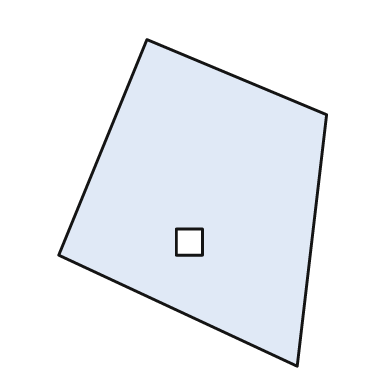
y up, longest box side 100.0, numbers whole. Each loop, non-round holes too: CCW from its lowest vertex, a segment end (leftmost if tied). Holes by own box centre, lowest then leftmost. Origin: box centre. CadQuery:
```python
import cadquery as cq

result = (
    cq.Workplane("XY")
    .moveTo(32.0, -50.0)
    .lineTo(41.0, 27.0)
    .lineTo(-14.0, 50.0)
    .lineTo(-41.0, -16.0)
    .close()
    .moveTo(-5.0, -16.0)
    .lineTo(3.0, -16.0)
    .lineTo(3.0, -8.0)
    .lineTo(-5.0, -8.0)
    .close()
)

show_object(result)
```